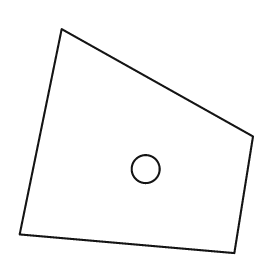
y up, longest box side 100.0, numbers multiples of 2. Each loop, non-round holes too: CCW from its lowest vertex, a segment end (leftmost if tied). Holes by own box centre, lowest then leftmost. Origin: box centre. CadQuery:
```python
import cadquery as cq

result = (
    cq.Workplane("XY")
    .moveTo(42.0, -48.0)
    .lineTo(50.0, 2.0)
    .lineTo(-32.0, 48.0)
    .lineTo(-50.0, -40.0)
    .close()
    .moveTo(4.0, -12.0)
    .circle(6.0)
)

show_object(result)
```